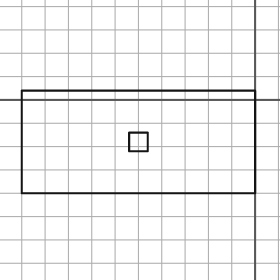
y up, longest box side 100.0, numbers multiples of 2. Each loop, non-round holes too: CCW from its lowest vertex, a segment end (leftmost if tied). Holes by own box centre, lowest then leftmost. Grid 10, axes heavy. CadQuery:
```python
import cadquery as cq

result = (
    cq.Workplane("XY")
    .moveTo(-100.0, -40.0)
    .lineTo(0.0, -40.0)
    .lineTo(0.0, 4.0)
    .lineTo(-100.0, 4.0)
    .close()
    .moveTo(-54.0, -22.0)
    .lineTo(-46.0, -22.0)
    .lineTo(-46.0, -14.0)
    .lineTo(-54.0, -14.0)
    .close()
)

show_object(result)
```